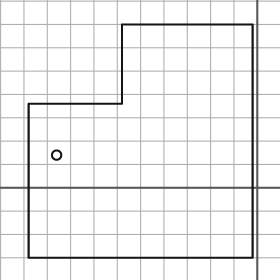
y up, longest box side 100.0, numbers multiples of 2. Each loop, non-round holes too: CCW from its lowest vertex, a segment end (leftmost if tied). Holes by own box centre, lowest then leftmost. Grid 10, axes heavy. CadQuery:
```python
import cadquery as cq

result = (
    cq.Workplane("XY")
    .moveTo(-98.0, -30.0)
    .lineTo(-2.0, -30.0)
    .lineTo(-2.0, 70.0)
    .lineTo(-58.0, 70.0)
    .lineTo(-58.0, 36.0)
    .lineTo(-98.0, 36.0)
    .close()
    .moveTo(-86.0, 14.0)
    .circle(2.0)
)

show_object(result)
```